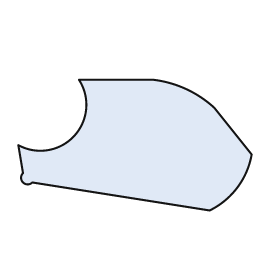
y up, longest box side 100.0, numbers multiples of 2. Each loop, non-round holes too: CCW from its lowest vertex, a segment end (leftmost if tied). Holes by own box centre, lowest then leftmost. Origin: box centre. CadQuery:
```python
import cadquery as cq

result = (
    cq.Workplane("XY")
    .moveTo(32.0, -28.0)
    .threePointArc((44.0, -18.0), (50.0, -4.0))
    .lineTo(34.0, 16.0)
    .threePointArc((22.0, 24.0), (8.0, 28.0))
    .lineTo(-24.0, 28.0)
    .threePointArc((-26.0, 4.0), (-50.0, 0.0))
    .lineTo(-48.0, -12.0)
    .threePointArc((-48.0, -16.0), (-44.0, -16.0))
    .close()
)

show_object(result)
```